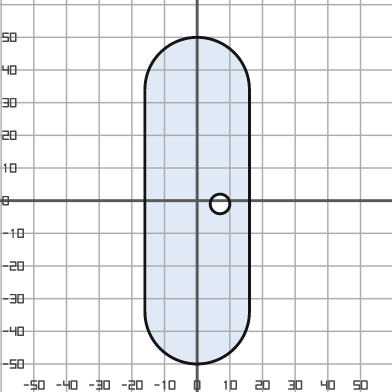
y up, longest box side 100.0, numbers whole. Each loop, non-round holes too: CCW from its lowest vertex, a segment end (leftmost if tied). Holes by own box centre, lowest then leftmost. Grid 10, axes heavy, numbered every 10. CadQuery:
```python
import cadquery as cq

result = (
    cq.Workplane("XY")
    .moveTo(-16.0, -34.0)
    .threePointArc((0.0, -50.0), (16.0, -34.0))
    .lineTo(16.0, 34.0)
    .threePointArc((0.0, 50.0), (-16.0, 34.0))
    .close()
    .moveTo(7.0, -1.0)
    .circle(3.0)
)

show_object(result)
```